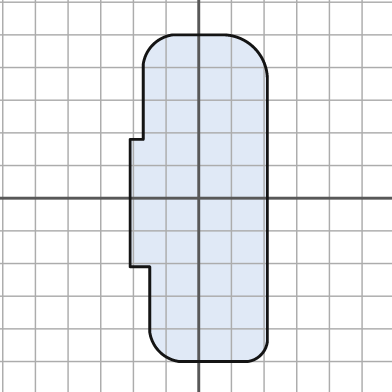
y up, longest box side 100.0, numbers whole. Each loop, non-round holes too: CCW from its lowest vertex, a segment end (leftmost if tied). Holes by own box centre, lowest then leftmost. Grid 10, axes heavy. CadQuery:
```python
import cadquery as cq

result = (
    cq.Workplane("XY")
    .moveTo(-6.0, -50.0)
    .lineTo(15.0, -50.0)
    .threePointArc((19.0, -48.0), (21.0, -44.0))
    .lineTo(21.0, 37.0)
    .threePointArc((17.0, 46.0), (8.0, 50.0))
    .lineTo(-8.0, 50.0)
    .threePointArc((-14.0, 47.0), (-17.0, 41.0))
    .lineTo(-17.0, 18.0)
    .lineTo(-21.0, 18.0)
    .lineTo(-21.0, -21.0)
    .lineTo(-15.0, -21.0)
    .lineTo(-15.0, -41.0)
    .threePointArc((-12.0, -47.0), (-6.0, -50.0))
    .close()
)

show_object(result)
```